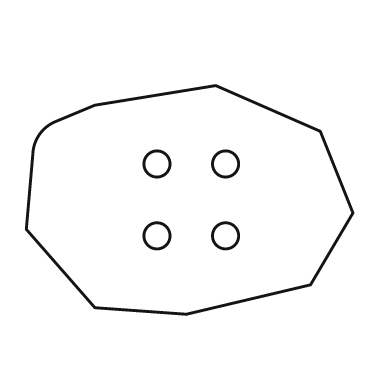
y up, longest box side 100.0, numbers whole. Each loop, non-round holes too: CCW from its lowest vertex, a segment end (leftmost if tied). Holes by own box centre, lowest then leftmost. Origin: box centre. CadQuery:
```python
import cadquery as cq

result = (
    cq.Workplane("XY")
    .moveTo(-1.0, -35.0)
    .lineTo(37.0, -26.0)
    .lineTo(50.0, -4.0)
    .lineTo(40.0, 21.0)
    .lineTo(8.0, 35.0)
    .lineTo(-29.0, 29.0)
    .lineTo(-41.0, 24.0)
    .threePointArc((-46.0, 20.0), (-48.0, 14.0))
    .lineTo(-50.0, -9.0)
    .lineTo(-29.0, -33.0)
    .close()
    .moveTo(-10.0, -11.0)
    .circle(4.0)
    .moveTo(11.0, -11.0)
    .circle(4.0)
    .moveTo(-10.0, 11.0)
    .circle(4.0)
    .moveTo(11.0, 11.0)
    .circle(4.0)
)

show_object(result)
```